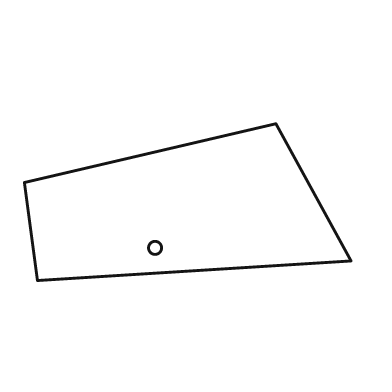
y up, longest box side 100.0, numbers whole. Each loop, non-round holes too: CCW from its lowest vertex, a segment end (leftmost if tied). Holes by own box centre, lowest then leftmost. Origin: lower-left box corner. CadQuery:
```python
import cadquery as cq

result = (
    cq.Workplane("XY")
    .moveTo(4.0, 0.0)
    .lineTo(100.0, 6.0)
    .lineTo(77.0, 48.0)
    .lineTo(0.0, 30.0)
    .close()
    .moveTo(40.0, 10.0)
    .circle(2.0)
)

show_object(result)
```